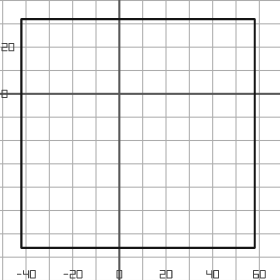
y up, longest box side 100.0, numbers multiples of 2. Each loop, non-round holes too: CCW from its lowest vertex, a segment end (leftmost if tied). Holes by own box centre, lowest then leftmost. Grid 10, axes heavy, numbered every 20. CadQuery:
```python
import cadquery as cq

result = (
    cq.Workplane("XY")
    .moveTo(-42.0, -66.0)
    .lineTo(58.0, -66.0)
    .lineTo(58.0, 32.0)
    .lineTo(-42.0, 32.0)
    .close()
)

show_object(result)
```